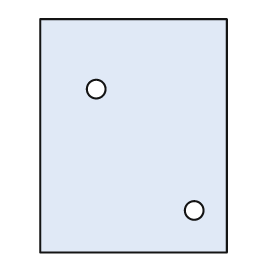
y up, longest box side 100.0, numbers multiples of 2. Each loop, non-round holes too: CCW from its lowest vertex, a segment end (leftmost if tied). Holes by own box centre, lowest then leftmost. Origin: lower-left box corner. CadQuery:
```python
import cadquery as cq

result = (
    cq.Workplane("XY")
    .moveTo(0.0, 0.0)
    .lineTo(80.0, 0.0)
    .lineTo(80.0, 100.0)
    .lineTo(0.0, 100.0)
    .close()
    .moveTo(66.0, 18.0)
    .circle(4.0)
    .moveTo(24.0, 70.0)
    .circle(4.0)
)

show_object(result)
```